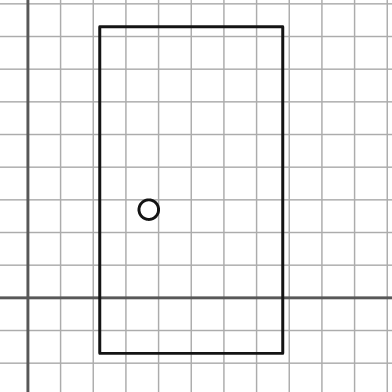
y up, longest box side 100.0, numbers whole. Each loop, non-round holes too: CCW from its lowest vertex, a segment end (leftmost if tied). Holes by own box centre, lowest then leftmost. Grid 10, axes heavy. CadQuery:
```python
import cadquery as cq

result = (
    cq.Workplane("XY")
    .moveTo(22.0, -17.0)
    .lineTo(78.0, -17.0)
    .lineTo(78.0, 83.0)
    .lineTo(22.0, 83.0)
    .close()
    .moveTo(37.0, 27.0)
    .circle(3.0)
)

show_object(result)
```